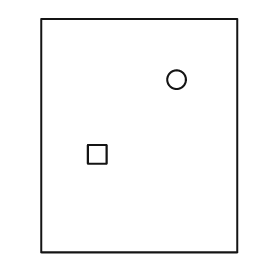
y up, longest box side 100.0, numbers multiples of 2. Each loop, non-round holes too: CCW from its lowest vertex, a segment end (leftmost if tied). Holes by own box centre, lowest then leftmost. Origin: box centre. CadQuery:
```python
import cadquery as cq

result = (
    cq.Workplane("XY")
    .moveTo(-42.0, -50.0)
    .lineTo(42.0, -50.0)
    .lineTo(42.0, 50.0)
    .lineTo(-42.0, 50.0)
    .close()
    .moveTo(-22.0, -12.0)
    .lineTo(-14.0, -12.0)
    .lineTo(-14.0, -4.0)
    .lineTo(-22.0, -4.0)
    .close()
    .moveTo(16.0, 24.0)
    .circle(4.0)
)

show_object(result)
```